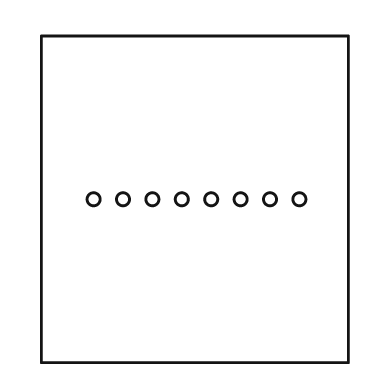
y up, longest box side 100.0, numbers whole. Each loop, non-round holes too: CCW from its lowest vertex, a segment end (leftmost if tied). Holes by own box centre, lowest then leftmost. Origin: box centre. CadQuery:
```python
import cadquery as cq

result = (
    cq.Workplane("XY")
    .moveTo(-47.0, -50.0)
    .lineTo(47.0, -50.0)
    .lineTo(47.0, 50.0)
    .lineTo(-47.0, 50.0)
    .close()
    .moveTo(-31.0, 0.0)
    .circle(2.0)
    .moveTo(-22.0, 0.0)
    .circle(2.0)
    .moveTo(-13.0, 0.0)
    .circle(2.0)
    .moveTo(-4.0, 0.0)
    .circle(2.0)
    .moveTo(5.0, 0.0)
    .circle(2.0)
    .moveTo(14.0, 0.0)
    .circle(2.0)
    .moveTo(23.0, 0.0)
    .circle(2.0)
    .moveTo(32.0, 0.0)
    .circle(2.0)
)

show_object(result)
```